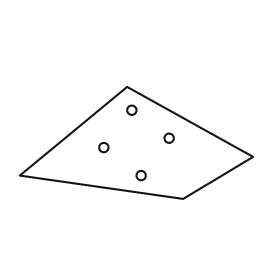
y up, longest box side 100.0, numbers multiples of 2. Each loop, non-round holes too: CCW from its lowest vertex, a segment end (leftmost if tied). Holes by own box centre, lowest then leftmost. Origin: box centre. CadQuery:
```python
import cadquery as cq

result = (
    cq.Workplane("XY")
    .moveTo(20.0, -24.0)
    .lineTo(50.0, -6.0)
    .lineTo(-4.0, 24.0)
    .lineTo(-50.0, -14.0)
    .close()
    .moveTo(2.0, -14.0)
    .circle(2.0)
    .moveTo(-14.0, -2.0)
    .circle(2.0)
    .moveTo(14.0, 2.0)
    .circle(2.0)
    .moveTo(-2.0, 14.0)
    .circle(2.0)
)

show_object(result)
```